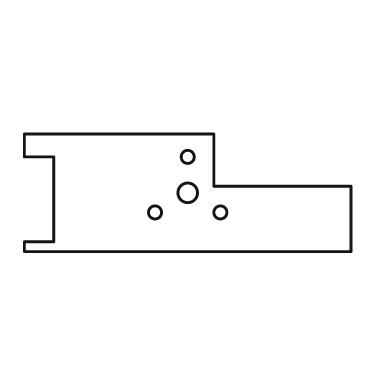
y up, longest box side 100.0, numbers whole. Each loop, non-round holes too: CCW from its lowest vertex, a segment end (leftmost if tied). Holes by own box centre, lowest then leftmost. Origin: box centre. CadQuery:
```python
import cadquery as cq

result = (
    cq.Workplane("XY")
    .moveTo(-50.0, -18.0)
    .lineTo(50.0, -18.0)
    .lineTo(50.0, 2.0)
    .lineTo(8.0, 2.0)
    .lineTo(8.0, 18.0)
    .lineTo(-50.0, 18.0)
    .lineTo(-50.0, 11.0)
    .lineTo(-41.0, 11.0)
    .lineTo(-41.0, -15.0)
    .lineTo(-50.0, -15.0)
    .close()
    .moveTo(-10.0, -6.0)
    .circle(2.0)
    .moveTo(10.0, -6.0)
    .circle(2.0)
    .moveTo(0.0, 0.0)
    .circle(3.0)
    .moveTo(0.0, 11.0)
    .circle(2.0)
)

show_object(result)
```